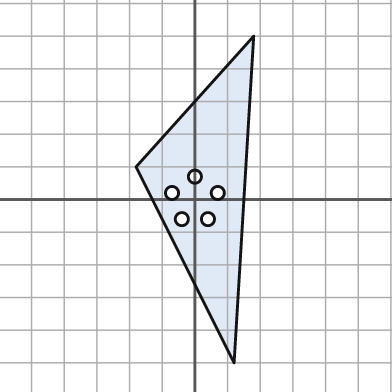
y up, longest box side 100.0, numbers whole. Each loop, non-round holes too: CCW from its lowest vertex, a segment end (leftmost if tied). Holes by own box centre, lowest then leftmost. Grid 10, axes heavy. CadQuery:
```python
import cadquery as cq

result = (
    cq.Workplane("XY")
    .moveTo(12.0, -50.0)
    .lineTo(18.0, 50.0)
    .lineTo(-18.0, 10.0)
    .close()
    .moveTo(-4.0, -6.0)
    .circle(2.0)
    .moveTo(4.0, -6.0)
    .circle(2.0)
    .moveTo(-7.0, 2.0)
    .circle(2.0)
    .moveTo(7.0, 2.0)
    .circle(2.0)
    .moveTo(0.0, 7.0)
    .circle(2.0)
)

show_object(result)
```